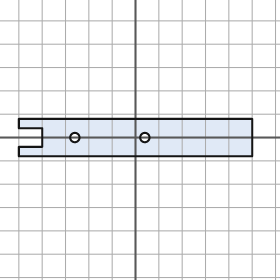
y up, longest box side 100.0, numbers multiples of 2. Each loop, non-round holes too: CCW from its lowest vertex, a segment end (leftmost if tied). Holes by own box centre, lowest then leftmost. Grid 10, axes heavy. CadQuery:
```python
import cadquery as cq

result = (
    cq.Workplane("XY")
    .moveTo(-50.0, -8.0)
    .lineTo(50.0, -8.0)
    .lineTo(50.0, 8.0)
    .lineTo(-50.0, 8.0)
    .lineTo(-50.0, 4.0)
    .lineTo(-40.0, 4.0)
    .lineTo(-40.0, -4.0)
    .lineTo(-50.0, -4.0)
    .close()
    .moveTo(-26.0, 0.0)
    .circle(2.0)
    .moveTo(4.0, 0.0)
    .circle(2.0)
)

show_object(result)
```